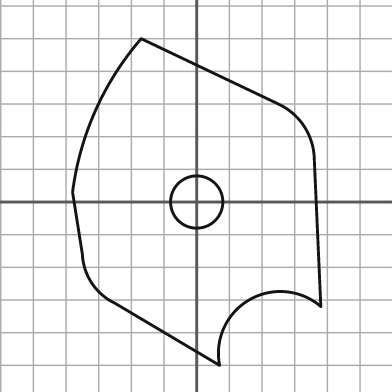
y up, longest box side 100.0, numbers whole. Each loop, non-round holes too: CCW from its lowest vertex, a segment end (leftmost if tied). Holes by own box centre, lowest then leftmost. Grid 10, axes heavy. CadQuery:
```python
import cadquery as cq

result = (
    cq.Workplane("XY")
    .moveTo(7.0, -50.0)
    .threePointArc((16.0, -30.0), (38.0, -32.0))
    .lineTo(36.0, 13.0)
    .threePointArc((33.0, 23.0), (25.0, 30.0))
    .lineTo(-17.0, 50.0)
    .threePointArc((-31.0, 28.0), (-38.0, 3.0))
    .lineTo(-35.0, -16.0)
    .threePointArc((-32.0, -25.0), (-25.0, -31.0))
    .close()
    .moveTo(0.0, 0.0)
    .circle(8.0)
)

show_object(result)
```